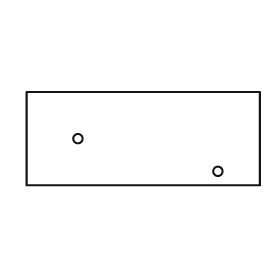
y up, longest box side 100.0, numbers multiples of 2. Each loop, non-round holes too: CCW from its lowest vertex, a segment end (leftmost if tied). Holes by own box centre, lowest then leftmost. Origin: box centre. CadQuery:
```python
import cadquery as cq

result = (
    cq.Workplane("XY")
    .moveTo(-50.0, -20.0)
    .lineTo(50.0, -20.0)
    .lineTo(50.0, 20.0)
    .lineTo(-50.0, 20.0)
    .close()
    .moveTo(32.0, -14.0)
    .circle(2.0)
    .moveTo(-28.0, 0.0)
    .circle(2.0)
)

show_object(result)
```